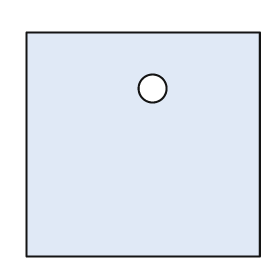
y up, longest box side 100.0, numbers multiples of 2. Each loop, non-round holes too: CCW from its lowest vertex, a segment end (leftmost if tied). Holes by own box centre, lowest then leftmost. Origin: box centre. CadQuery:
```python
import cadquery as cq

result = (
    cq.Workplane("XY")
    .moveTo(-50.0, -48.0)
    .lineTo(50.0, -48.0)
    .lineTo(50.0, 48.0)
    .lineTo(-50.0, 48.0)
    .close()
    .moveTo(4.0, 24.0)
    .circle(6.0)
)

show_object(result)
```